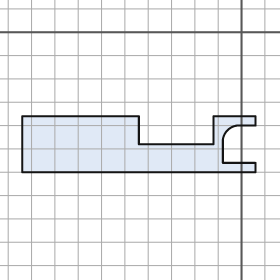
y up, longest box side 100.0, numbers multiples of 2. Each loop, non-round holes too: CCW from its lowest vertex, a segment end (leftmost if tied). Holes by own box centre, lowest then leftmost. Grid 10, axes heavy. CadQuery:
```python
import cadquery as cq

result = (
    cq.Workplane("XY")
    .moveTo(-94.0, -60.0)
    .lineTo(6.0, -60.0)
    .lineTo(6.0, -56.0)
    .lineTo(-8.0, -56.0)
    .lineTo(-8.0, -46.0)
    .threePointArc((-6.0, -42.0), (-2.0, -40.0))
    .lineTo(6.0, -40.0)
    .lineTo(6.0, -36.0)
    .lineTo(-12.0, -36.0)
    .lineTo(-12.0, -48.0)
    .lineTo(-44.0, -48.0)
    .lineTo(-44.0, -36.0)
    .lineTo(-94.0, -36.0)
    .close()
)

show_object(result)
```